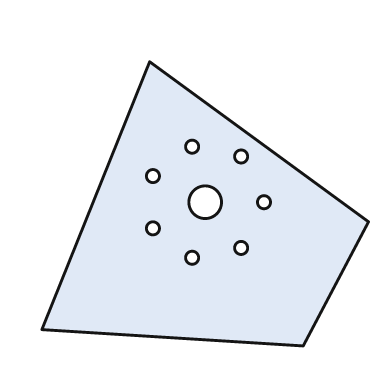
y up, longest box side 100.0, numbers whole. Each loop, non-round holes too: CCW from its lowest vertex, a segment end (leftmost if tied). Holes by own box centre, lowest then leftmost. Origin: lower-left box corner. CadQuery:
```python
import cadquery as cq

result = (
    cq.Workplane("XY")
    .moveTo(80.0, 0.0)
    .lineTo(100.0, 38.0)
    .lineTo(33.0, 87.0)
    .lineTo(0.0, 5.0)
    .close()
    .moveTo(46.0, 27.0)
    .circle(2.0)
    .moveTo(61.0, 30.0)
    .circle(2.0)
    .moveTo(34.0, 36.0)
    .circle(2.0)
    .moveTo(50.0, 44.0)
    .circle(5.0)
    .moveTo(68.0, 44.0)
    .circle(2.0)
    .moveTo(34.0, 52.0)
    .circle(2.0)
    .moveTo(61.0, 58.0)
    .circle(2.0)
    .moveTo(46.0, 61.0)
    .circle(2.0)
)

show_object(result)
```